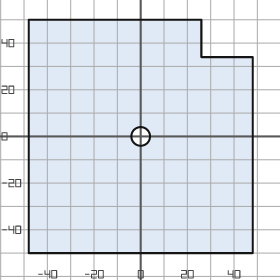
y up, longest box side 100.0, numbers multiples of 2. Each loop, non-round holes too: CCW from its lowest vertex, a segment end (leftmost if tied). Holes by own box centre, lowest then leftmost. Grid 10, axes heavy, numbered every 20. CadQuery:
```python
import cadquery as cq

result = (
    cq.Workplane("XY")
    .moveTo(-48.0, -50.0)
    .lineTo(48.0, -50.0)
    .lineTo(48.0, 34.0)
    .lineTo(26.0, 34.0)
    .lineTo(26.0, 50.0)
    .lineTo(-48.0, 50.0)
    .close()
    .moveTo(0.0, 0.0)
    .circle(4.0)
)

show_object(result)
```